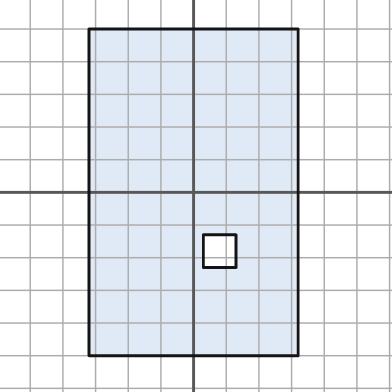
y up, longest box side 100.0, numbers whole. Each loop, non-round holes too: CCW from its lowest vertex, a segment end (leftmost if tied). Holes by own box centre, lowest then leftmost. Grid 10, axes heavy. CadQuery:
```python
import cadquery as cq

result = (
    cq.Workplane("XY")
    .moveTo(-32.0, -50.0)
    .lineTo(32.0, -50.0)
    .lineTo(32.0, 50.0)
    .lineTo(-32.0, 50.0)
    .close()
    .moveTo(3.0, -23.0)
    .lineTo(13.0, -23.0)
    .lineTo(13.0, -13.0)
    .lineTo(3.0, -13.0)
    .close()
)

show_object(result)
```